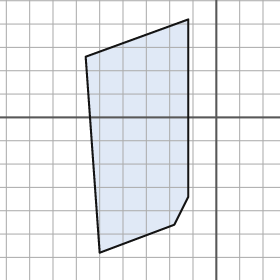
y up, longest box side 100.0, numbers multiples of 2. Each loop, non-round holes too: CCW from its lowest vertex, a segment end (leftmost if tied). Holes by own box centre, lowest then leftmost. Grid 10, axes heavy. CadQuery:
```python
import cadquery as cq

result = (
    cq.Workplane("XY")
    .moveTo(-50.0, -58.0)
    .lineTo(-18.0, -46.0)
    .lineTo(-12.0, -34.0)
    .lineTo(-12.0, 42.0)
    .lineTo(-56.0, 26.0)
    .close()
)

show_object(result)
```